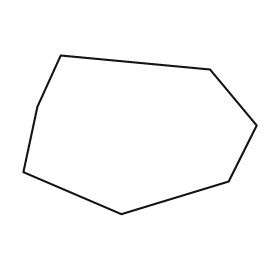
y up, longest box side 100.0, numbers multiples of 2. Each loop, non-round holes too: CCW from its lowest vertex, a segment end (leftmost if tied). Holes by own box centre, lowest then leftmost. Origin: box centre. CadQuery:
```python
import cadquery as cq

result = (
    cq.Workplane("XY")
    .moveTo(-8.0, -34.0)
    .lineTo(38.0, -20.0)
    .lineTo(50.0, 4.0)
    .lineTo(30.0, 28.0)
    .lineTo(-34.0, 34.0)
    .lineTo(-44.0, 12.0)
    .lineTo(-50.0, -16.0)
    .close()
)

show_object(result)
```